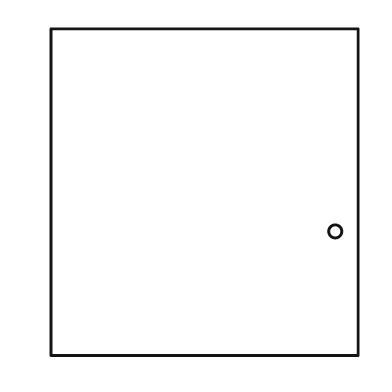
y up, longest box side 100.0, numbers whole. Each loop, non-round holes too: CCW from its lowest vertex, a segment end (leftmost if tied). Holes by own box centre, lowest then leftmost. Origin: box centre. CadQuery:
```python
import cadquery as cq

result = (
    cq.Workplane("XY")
    .moveTo(-47.0, -50.0)
    .lineTo(47.0, -50.0)
    .lineTo(47.0, 50.0)
    .lineTo(-47.0, 50.0)
    .close()
    .moveTo(40.0, -12.0)
    .circle(2.0)
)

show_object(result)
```